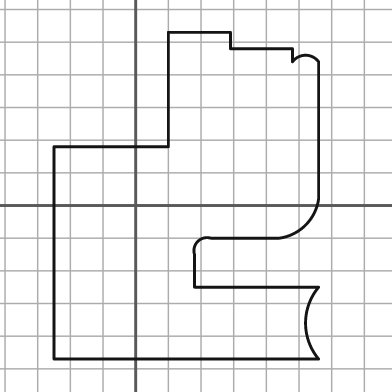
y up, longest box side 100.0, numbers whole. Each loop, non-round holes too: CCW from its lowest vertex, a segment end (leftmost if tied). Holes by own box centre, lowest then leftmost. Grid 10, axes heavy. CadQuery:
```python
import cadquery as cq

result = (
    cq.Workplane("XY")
    .moveTo(-25.0, -47.0)
    .lineTo(56.0, -47.0)
    .threePointArc((52.0, -36.0), (56.0, -25.0))
    .lineTo(18.0, -25.0)
    .lineTo(18.0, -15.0)
    .threePointArc((19.0, -11.0), (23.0, -10.0))
    .lineTo(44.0, -10.0)
    .threePointArc((52.0, -6.0), (56.0, 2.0))
    .lineTo(56.0, 44.0)
    .threePointArc((52.0, 46.0), (48.0, 44.0))
    .lineTo(48.0, 48.0)
    .lineTo(29.0, 48.0)
    .lineTo(29.0, 53.0)
    .lineTo(10.0, 53.0)
    .lineTo(10.0, 18.0)
    .lineTo(-25.0, 18.0)
    .close()
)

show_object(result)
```